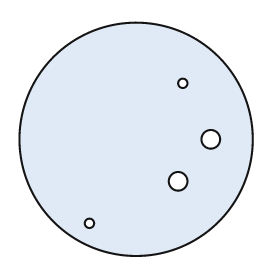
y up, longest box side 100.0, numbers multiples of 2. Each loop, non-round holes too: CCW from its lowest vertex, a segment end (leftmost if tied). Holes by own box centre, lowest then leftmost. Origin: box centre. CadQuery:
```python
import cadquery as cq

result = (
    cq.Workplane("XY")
    .moveTo(0.0, 0.0)
    .circle(50.0)
    .moveTo(-20.0, -36.0)
    .circle(2.0)
    .moveTo(18.0, -18.0)
    .circle(4.0)
    .moveTo(32.0, 0.0)
    .circle(4.0)
    .moveTo(20.0, 24.0)
    .circle(2.0)
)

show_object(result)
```